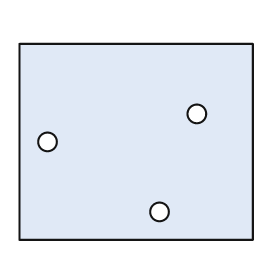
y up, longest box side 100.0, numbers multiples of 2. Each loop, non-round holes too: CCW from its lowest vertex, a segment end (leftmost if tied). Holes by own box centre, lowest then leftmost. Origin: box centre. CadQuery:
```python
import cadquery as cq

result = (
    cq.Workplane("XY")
    .moveTo(-50.0, -42.0)
    .lineTo(50.0, -42.0)
    .lineTo(50.0, 42.0)
    .lineTo(-50.0, 42.0)
    .close()
    .moveTo(10.0, -30.0)
    .circle(4.0)
    .moveTo(-38.0, 0.0)
    .circle(4.0)
    .moveTo(26.0, 12.0)
    .circle(4.0)
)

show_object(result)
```